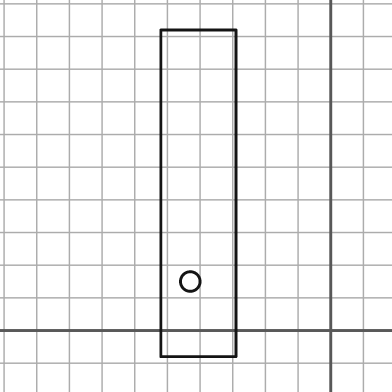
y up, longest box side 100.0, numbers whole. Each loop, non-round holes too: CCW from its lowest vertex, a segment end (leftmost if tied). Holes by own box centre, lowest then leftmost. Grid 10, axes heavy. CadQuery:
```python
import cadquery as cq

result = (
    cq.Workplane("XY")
    .moveTo(-52.0, -8.0)
    .lineTo(-29.0, -8.0)
    .lineTo(-29.0, 92.0)
    .lineTo(-52.0, 92.0)
    .close()
    .moveTo(-43.0, 15.0)
    .circle(3.0)
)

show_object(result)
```